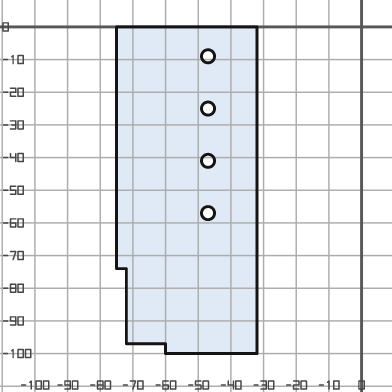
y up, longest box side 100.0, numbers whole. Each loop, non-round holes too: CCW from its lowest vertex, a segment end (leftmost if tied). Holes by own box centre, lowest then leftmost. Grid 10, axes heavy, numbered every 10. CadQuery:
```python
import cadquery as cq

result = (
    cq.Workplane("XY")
    .moveTo(-60.0, -100.0)
    .lineTo(-32.0, -100.0)
    .lineTo(-32.0, 0.0)
    .lineTo(-75.0, 0.0)
    .lineTo(-75.0, -74.0)
    .lineTo(-72.0, -74.0)
    .lineTo(-72.0, -97.0)
    .lineTo(-60.0, -97.0)
    .close()
    .moveTo(-47.0, -57.0)
    .circle(2.0)
    .moveTo(-47.0, -41.0)
    .circle(2.0)
    .moveTo(-47.0, -25.0)
    .circle(2.0)
    .moveTo(-47.0, -9.0)
    .circle(2.0)
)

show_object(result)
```